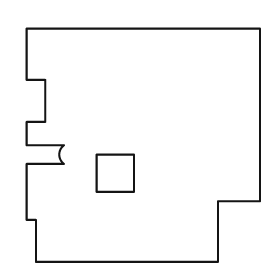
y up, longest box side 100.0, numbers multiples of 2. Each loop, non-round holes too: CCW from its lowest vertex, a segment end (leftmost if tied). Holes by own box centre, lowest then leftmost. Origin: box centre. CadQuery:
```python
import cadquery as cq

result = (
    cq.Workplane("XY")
    .moveTo(-46.0, -50.0)
    .lineTo(32.0, -50.0)
    .lineTo(32.0, -24.0)
    .lineTo(50.0, -24.0)
    .lineTo(50.0, 50.0)
    .lineTo(-50.0, 50.0)
    .lineTo(-50.0, 28.0)
    .lineTo(-42.0, 28.0)
    .lineTo(-42.0, 10.0)
    .lineTo(-50.0, 10.0)
    .lineTo(-50.0, 0.0)
    .lineTo(-34.0, 0.0)
    .threePointArc((-36.0, -4.0), (-34.0, -8.0))
    .lineTo(-50.0, -8.0)
    .lineTo(-50.0, -32.0)
    .lineTo(-46.0, -32.0)
    .close()
    .moveTo(-20.0, -20.0)
    .lineTo(-4.0, -20.0)
    .lineTo(-4.0, -4.0)
    .lineTo(-20.0, -4.0)
    .close()
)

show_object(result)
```